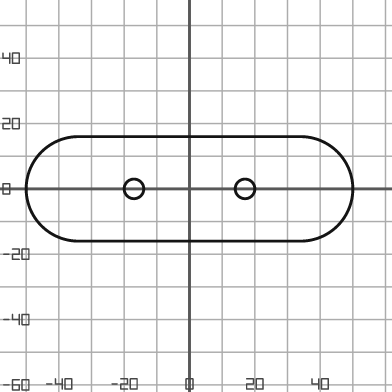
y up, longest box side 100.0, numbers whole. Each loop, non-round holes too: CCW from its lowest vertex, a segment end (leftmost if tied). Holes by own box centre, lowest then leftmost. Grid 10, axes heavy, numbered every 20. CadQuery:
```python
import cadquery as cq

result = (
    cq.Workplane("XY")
    .moveTo(-34.0, -16.0)
    .lineTo(34.0, -16.0)
    .threePointArc((50.0, 0.0), (34.0, 16.0))
    .lineTo(-34.0, 16.0)
    .threePointArc((-50.0, 0.0), (-34.0, -16.0))
    .close()
    .moveTo(-17.0, 0.0)
    .circle(3.0)
    .moveTo(17.0, 0.0)
    .circle(3.0)
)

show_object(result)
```